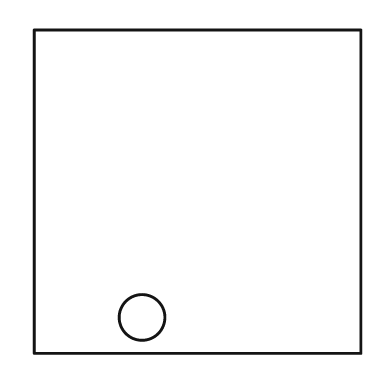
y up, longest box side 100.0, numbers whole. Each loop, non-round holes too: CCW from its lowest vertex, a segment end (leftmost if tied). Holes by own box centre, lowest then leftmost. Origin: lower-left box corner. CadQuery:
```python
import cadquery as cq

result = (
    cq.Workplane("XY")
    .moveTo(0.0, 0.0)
    .lineTo(100.0, 0.0)
    .lineTo(100.0, 99.0)
    .lineTo(0.0, 99.0)
    .close()
    .moveTo(33.0, 11.0)
    .circle(7.0)
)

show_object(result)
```